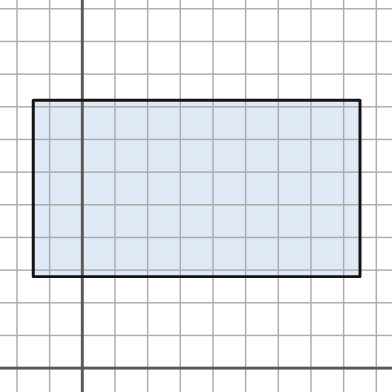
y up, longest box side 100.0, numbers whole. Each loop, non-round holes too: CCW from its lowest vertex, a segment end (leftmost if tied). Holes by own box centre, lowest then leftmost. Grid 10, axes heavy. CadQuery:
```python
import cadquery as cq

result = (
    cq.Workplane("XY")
    .moveTo(-15.0, 28.0)
    .lineTo(85.0, 28.0)
    .lineTo(85.0, 82.0)
    .lineTo(-15.0, 82.0)
    .close()
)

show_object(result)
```